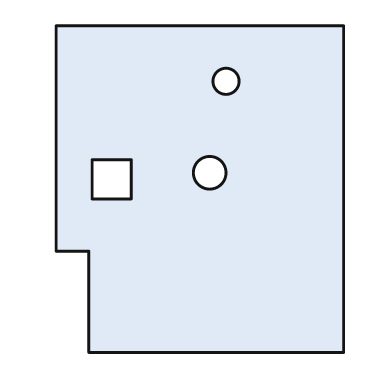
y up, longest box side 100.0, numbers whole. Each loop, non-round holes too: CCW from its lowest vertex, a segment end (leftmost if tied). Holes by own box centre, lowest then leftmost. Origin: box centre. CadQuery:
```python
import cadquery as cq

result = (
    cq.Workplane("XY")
    .moveTo(-34.0, -50.0)
    .lineTo(44.0, -50.0)
    .lineTo(44.0, 50.0)
    .lineTo(-44.0, 50.0)
    .lineTo(-44.0, -19.0)
    .lineTo(-34.0, -19.0)
    .close()
    .moveTo(-33.0, -3.0)
    .lineTo(-21.0, -3.0)
    .lineTo(-21.0, 9.0)
    .lineTo(-33.0, 9.0)
    .close()
    .moveTo(3.0, 5.0)
    .circle(5.0)
    .moveTo(8.0, 33.0)
    .circle(4.0)
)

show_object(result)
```